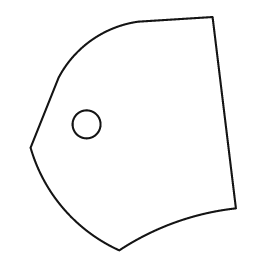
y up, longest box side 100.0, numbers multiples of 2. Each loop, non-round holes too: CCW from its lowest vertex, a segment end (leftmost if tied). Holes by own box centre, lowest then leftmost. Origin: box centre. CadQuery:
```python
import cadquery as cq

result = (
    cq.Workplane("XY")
    .moveTo(-6.0, -50.0)
    .threePointArc((18.0, -38.0), (44.0, -32.0))
    .lineTo(34.0, 50.0)
    .lineTo(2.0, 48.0)
    .threePointArc((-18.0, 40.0), (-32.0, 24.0))
    .lineTo(-44.0, -6.0)
    .threePointArc((-30.0, -32.0), (-6.0, -50.0))
    .close()
    .moveTo(-20.0, 4.0)
    .circle(6.0)
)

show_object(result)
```